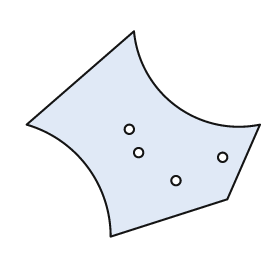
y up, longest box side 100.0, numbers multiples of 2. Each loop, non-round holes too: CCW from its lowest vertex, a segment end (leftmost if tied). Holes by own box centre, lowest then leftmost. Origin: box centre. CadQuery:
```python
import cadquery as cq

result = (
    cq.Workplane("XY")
    .moveTo(-14.0, -44.0)
    .lineTo(36.0, -28.0)
    .lineTo(50.0, 4.0)
    .threePointArc((14.0, 12.0), (-4.0, 44.0))
    .lineTo(-50.0, 4.0)
    .threePointArc((-24.0, -14.0), (-14.0, -44.0))
    .close()
    .moveTo(14.0, -20.0)
    .circle(2.0)
    .moveTo(34.0, -10.0)
    .circle(2.0)
    .moveTo(-2.0, -8.0)
    .circle(2.0)
    .moveTo(-6.0, 2.0)
    .circle(2.0)
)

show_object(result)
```